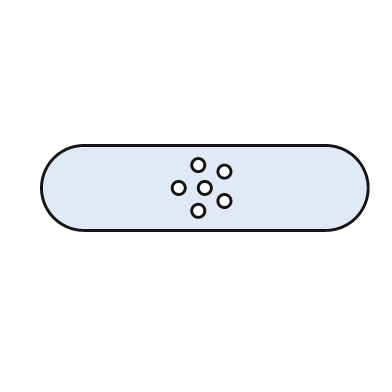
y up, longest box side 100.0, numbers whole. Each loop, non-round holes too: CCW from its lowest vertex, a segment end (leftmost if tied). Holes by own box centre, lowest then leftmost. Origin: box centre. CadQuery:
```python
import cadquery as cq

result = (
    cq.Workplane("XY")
    .moveTo(-37.0, -13.0)
    .lineTo(37.0, -13.0)
    .threePointArc((50.0, 0.0), (37.0, 13.0))
    .lineTo(-37.0, 13.0)
    .threePointArc((-50.0, 0.0), (-37.0, -13.0))
    .close()
    .moveTo(-2.0, -7.0)
    .circle(2.0)
    .moveTo(6.0, -4.0)
    .circle(2.0)
    .moveTo(-8.0, 0.0)
    .circle(2.0)
    .moveTo(0.0, 0.0)
    .circle(2.0)
    .moveTo(6.0, 5.0)
    .circle(2.0)
    .moveTo(-2.0, 7.0)
    .circle(2.0)
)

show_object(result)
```